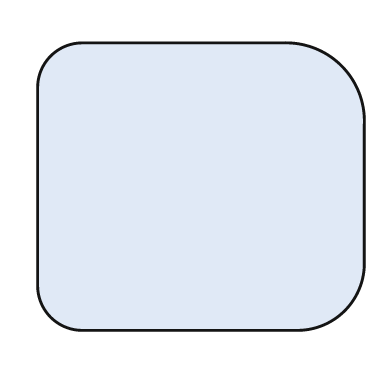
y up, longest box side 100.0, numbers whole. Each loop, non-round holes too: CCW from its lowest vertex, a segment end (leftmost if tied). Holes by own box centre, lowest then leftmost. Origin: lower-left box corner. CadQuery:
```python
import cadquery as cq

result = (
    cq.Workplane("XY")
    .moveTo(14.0, 0.0)
    .lineTo(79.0, 0.0)
    .threePointArc((94.0, 6.0), (100.0, 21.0))
    .lineTo(100.0, 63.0)
    .threePointArc((93.0, 81.0), (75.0, 88.0))
    .lineTo(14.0, 88.0)
    .threePointArc((4.0, 84.0), (0.0, 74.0))
    .lineTo(0.0, 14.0)
    .threePointArc((4.0, 4.0), (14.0, 0.0))
    .close()
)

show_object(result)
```